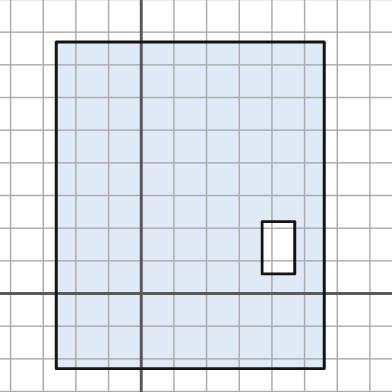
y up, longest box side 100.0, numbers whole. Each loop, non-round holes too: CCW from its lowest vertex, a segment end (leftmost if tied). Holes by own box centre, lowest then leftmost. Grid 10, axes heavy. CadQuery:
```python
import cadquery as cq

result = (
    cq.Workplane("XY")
    .moveTo(-26.0, -23.0)
    .lineTo(56.0, -23.0)
    .lineTo(56.0, 77.0)
    .lineTo(-26.0, 77.0)
    .close()
    .moveTo(37.0, 6.0)
    .lineTo(47.0, 6.0)
    .lineTo(47.0, 22.0)
    .lineTo(37.0, 22.0)
    .close()
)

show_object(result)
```